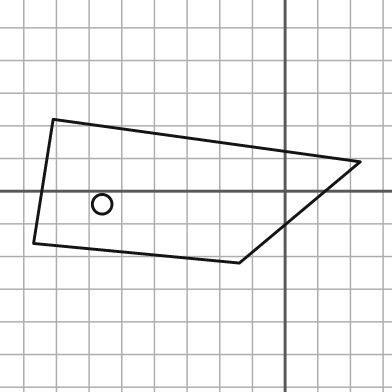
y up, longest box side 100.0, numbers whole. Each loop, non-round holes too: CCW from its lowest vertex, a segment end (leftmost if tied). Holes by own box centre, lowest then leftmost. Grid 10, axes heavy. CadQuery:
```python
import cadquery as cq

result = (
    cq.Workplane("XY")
    .moveTo(-14.0, -22.0)
    .lineTo(23.0, 9.0)
    .lineTo(-71.0, 22.0)
    .lineTo(-77.0, -16.0)
    .close()
    .moveTo(-56.0, -4.0)
    .circle(3.0)
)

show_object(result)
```